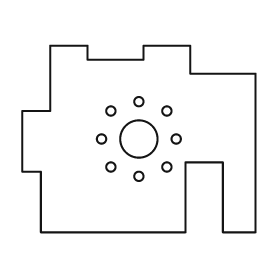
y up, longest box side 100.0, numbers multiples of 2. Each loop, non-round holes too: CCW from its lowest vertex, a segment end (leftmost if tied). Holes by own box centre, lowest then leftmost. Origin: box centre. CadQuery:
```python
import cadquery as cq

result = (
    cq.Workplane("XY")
    .moveTo(-42.0, -40.0)
    .lineTo(20.0, -40.0)
    .lineTo(20.0, -10.0)
    .lineTo(36.0, -10.0)
    .lineTo(36.0, -40.0)
    .lineTo(50.0, -40.0)
    .lineTo(50.0, 28.0)
    .lineTo(22.0, 28.0)
    .lineTo(22.0, 40.0)
    .lineTo(2.0, 40.0)
    .lineTo(2.0, 34.0)
    .lineTo(-22.0, 34.0)
    .lineTo(-22.0, 40.0)
    .lineTo(-38.0, 40.0)
    .lineTo(-38.0, 12.0)
    .lineTo(-50.0, 12.0)
    .lineTo(-50.0, -14.0)
    .lineTo(-42.0, -14.0)
    .close()
    .moveTo(0.0, -16.0)
    .circle(2.0)
    .moveTo(-12.0, -12.0)
    .circle(2.0)
    .moveTo(12.0, -12.0)
    .circle(2.0)
    .moveTo(-16.0, 0.0)
    .circle(2.0)
    .moveTo(0.0, 0.0)
    .circle(8.0)
    .moveTo(16.0, 0.0)
    .circle(2.0)
    .moveTo(-12.0, 12.0)
    .circle(2.0)
    .moveTo(12.0, 12.0)
    .circle(2.0)
    .moveTo(0.0, 16.0)
    .circle(2.0)
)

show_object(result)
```